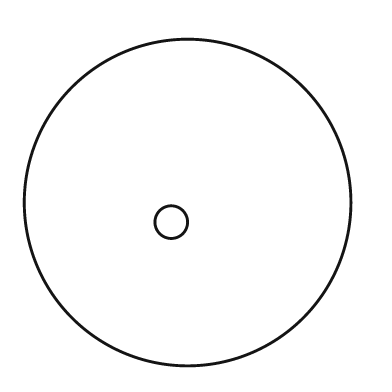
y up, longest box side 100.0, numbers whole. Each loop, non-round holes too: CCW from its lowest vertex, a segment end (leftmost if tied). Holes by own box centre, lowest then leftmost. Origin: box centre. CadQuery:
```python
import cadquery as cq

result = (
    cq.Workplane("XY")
    .moveTo(0.0, 0.0)
    .circle(50.0)
    .moveTo(-5.0, -6.0)
    .circle(5.0)
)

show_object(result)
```